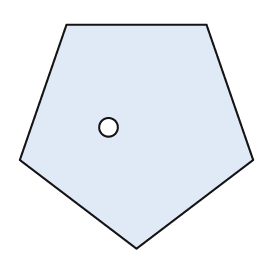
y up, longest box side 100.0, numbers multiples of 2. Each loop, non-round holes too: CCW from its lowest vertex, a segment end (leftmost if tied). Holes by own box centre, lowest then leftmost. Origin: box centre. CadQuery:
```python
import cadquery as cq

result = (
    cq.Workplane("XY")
    .moveTo(0.0, -48.0)
    .lineTo(50.0, -10.0)
    .lineTo(30.0, 48.0)
    .lineTo(-30.0, 48.0)
    .lineTo(-50.0, -10.0)
    .close()
    .moveTo(-12.0, 4.0)
    .circle(4.0)
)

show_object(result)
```